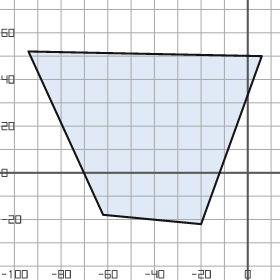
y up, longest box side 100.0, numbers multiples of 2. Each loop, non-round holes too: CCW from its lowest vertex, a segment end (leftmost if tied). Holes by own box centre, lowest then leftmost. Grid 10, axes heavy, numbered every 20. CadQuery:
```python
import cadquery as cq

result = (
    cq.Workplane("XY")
    .moveTo(-20.0, -22.0)
    .lineTo(6.0, 50.0)
    .lineTo(-94.0, 52.0)
    .lineTo(-62.0, -18.0)
    .close()
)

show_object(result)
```